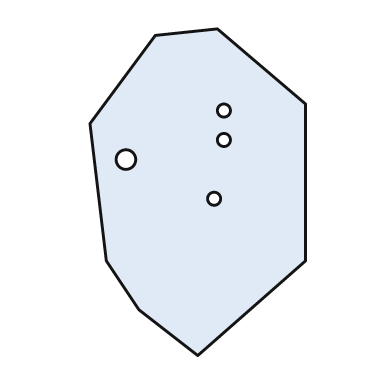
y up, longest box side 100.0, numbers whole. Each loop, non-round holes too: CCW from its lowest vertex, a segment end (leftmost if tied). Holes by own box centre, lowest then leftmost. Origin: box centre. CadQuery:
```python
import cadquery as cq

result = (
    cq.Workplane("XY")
    .moveTo(0.0, -50.0)
    .lineTo(33.0, -21.0)
    .lineTo(33.0, 27.0)
    .lineTo(6.0, 50.0)
    .lineTo(-13.0, 48.0)
    .lineTo(-33.0, 21.0)
    .lineTo(-28.0, -21.0)
    .lineTo(-18.0, -36.0)
    .close()
    .moveTo(5.0, -2.0)
    .circle(2.0)
    .moveTo(-22.0, 10.0)
    .circle(3.0)
    .moveTo(8.0, 16.0)
    .circle(2.0)
    .moveTo(8.0, 25.0)
    .circle(2.0)
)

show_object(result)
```